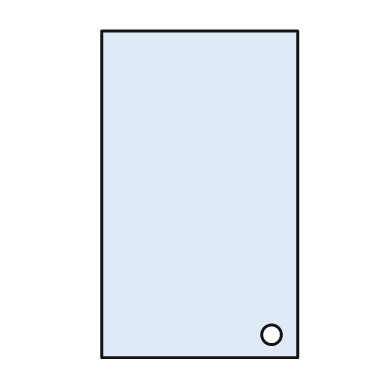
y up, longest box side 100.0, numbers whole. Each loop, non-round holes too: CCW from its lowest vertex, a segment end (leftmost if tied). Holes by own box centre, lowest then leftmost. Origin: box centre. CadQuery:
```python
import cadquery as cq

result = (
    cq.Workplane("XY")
    .moveTo(-30.0, -50.0)
    .lineTo(30.0, -50.0)
    .lineTo(30.0, 50.0)
    .lineTo(-30.0, 50.0)
    .close()
    .moveTo(22.0, -43.0)
    .circle(3.0)
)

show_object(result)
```